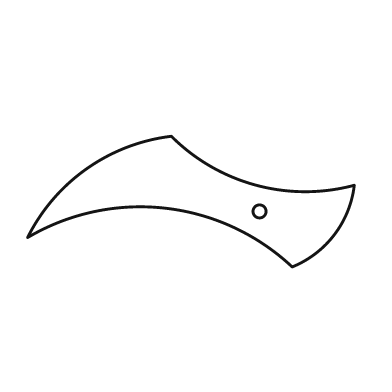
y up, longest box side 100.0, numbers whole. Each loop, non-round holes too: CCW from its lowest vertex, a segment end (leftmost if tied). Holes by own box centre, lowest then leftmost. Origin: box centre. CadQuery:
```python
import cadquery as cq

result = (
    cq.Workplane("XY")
    .moveTo(31.0, -20.0)
    .threePointArc((44.0, -10.0), (50.0, 5.0))
    .threePointArc((20.0, 5.0), (-6.0, 20.0))
    .threePointArc((-32.0, 10.0), (-50.0, -11.0))
    .threePointArc((-8.0, -2.0), (31.0, -20.0))
    .close()
    .moveTo(21.0, -3.0)
    .circle(2.0)
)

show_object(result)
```